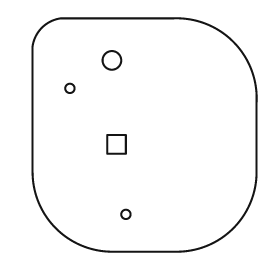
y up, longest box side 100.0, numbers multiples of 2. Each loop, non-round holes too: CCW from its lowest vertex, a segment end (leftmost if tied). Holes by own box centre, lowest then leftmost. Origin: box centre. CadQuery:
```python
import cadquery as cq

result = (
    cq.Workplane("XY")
    .moveTo(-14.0, -50.0)
    .lineTo(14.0, -50.0)
    .threePointArc((38.0, -40.0), (48.0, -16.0))
    .lineTo(48.0, 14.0)
    .threePointArc((38.0, 40.0), (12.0, 50.0))
    .lineTo(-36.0, 50.0)
    .threePointArc((-44.0, 46.0), (-48.0, 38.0))
    .lineTo(-48.0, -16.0)
    .threePointArc((-38.0, -40.0), (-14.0, -50.0))
    .close()
    .moveTo(-8.0, -34.0)
    .circle(2.0)
    .moveTo(-16.0, -8.0)
    .lineTo(-8.0, -8.0)
    .lineTo(-8.0, 0.0)
    .lineTo(-16.0, 0.0)
    .close()
    .moveTo(-32.0, 20.0)
    .circle(2.0)
    .moveTo(-14.0, 32.0)
    .circle(4.0)
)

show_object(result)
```